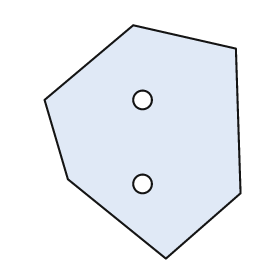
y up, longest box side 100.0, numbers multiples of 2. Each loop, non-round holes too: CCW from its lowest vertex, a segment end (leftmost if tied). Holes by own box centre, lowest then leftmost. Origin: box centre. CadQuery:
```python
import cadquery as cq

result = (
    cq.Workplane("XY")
    .moveTo(10.0, -50.0)
    .lineTo(42.0, -22.0)
    .lineTo(40.0, 40.0)
    .lineTo(-4.0, 50.0)
    .lineTo(-42.0, 18.0)
    .lineTo(-32.0, -16.0)
    .close()
    .moveTo(0.0, -18.0)
    .circle(4.0)
    .moveTo(0.0, 18.0)
    .circle(4.0)
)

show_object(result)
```